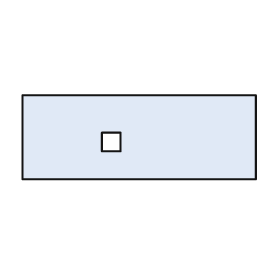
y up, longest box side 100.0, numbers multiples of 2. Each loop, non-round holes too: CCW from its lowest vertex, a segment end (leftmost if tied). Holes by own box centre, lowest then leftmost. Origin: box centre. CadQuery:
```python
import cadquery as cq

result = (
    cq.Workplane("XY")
    .moveTo(-50.0, -18.0)
    .lineTo(50.0, -18.0)
    .lineTo(50.0, 18.0)
    .lineTo(-50.0, 18.0)
    .close()
    .moveTo(-16.0, -6.0)
    .lineTo(-8.0, -6.0)
    .lineTo(-8.0, 2.0)
    .lineTo(-16.0, 2.0)
    .close()
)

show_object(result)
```